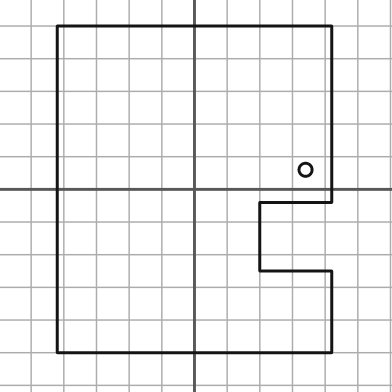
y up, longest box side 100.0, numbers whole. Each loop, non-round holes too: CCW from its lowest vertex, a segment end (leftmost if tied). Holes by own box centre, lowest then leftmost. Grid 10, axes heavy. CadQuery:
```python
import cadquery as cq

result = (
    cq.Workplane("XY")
    .moveTo(-42.0, -50.0)
    .lineTo(42.0, -50.0)
    .lineTo(42.0, -25.0)
    .lineTo(20.0, -25.0)
    .lineTo(20.0, -4.0)
    .lineTo(42.0, -4.0)
    .lineTo(42.0, 50.0)
    .lineTo(-42.0, 50.0)
    .close()
    .moveTo(34.0, 6.0)
    .circle(2.0)
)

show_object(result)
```